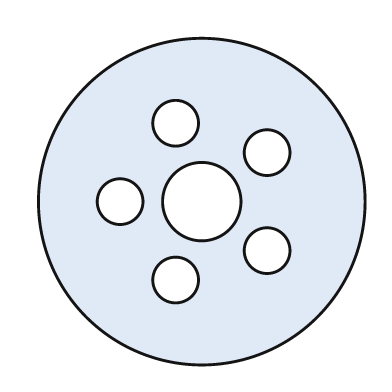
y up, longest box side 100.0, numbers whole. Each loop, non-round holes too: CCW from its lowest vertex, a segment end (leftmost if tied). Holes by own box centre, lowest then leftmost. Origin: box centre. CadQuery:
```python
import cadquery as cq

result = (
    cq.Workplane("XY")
    .moveTo(0.0, 0.0)
    .circle(50.0)
    .moveTo(-8.0, -24.0)
    .circle(7.0)
    .moveTo(20.0, -15.0)
    .circle(7.0)
    .moveTo(-25.0, 0.0)
    .circle(7.0)
    .moveTo(0.0, 0.0)
    .circle(12.0)
    .moveTo(20.0, 15.0)
    .circle(7.0)
    .moveTo(-8.0, 24.0)
    .circle(7.0)
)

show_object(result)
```